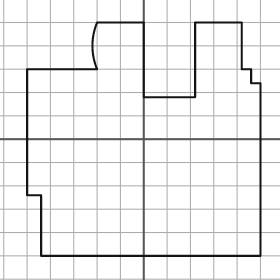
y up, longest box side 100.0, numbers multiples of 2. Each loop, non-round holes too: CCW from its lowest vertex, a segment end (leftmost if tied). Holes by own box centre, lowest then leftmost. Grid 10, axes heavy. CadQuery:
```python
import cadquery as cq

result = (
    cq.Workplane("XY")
    .moveTo(-44.0, -50.0)
    .lineTo(50.0, -50.0)
    .lineTo(50.0, 24.0)
    .lineTo(46.0, 24.0)
    .lineTo(46.0, 30.0)
    .lineTo(42.0, 30.0)
    .lineTo(42.0, 50.0)
    .lineTo(22.0, 50.0)
    .lineTo(22.0, 18.0)
    .lineTo(0.0, 18.0)
    .lineTo(0.0, 50.0)
    .lineTo(-20.0, 50.0)
    .threePointArc((-22.0, 40.0), (-20.0, 30.0))
    .lineTo(-50.0, 30.0)
    .lineTo(-50.0, -24.0)
    .lineTo(-44.0, -24.0)
    .close()
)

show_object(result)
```